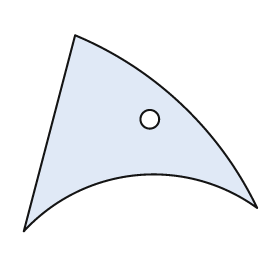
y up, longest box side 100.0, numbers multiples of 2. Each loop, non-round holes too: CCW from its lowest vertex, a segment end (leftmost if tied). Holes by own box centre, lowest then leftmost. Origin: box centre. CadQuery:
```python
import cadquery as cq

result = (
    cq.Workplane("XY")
    .moveTo(-50.0, -42.0)
    .threePointArc((-2.0, -18.0), (50.0, -32.0))
    .threePointArc((18.0, 12.0), (-28.0, 42.0))
    .close()
    .moveTo(4.0, 6.0)
    .circle(4.0)
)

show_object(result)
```